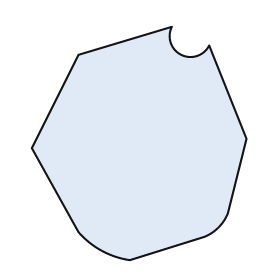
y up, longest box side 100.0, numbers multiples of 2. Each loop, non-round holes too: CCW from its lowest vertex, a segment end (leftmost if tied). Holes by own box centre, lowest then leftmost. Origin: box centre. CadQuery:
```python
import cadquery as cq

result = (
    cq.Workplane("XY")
    .moveTo(-4.0, -50.0)
    .lineTo(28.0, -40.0)
    .threePointArc((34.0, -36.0), (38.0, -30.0))
    .lineTo(46.0, 2.0)
    .lineTo(30.0, 42.0)
    .threePointArc((18.0, 38.0), (14.0, 50.0))
    .lineTo(-26.0, 38.0)
    .lineTo(-46.0, -2.0)
    .lineTo(-26.0, -38.0)
    .threePointArc((-16.0, -46.0), (-4.0, -50.0))
    .close()
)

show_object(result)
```